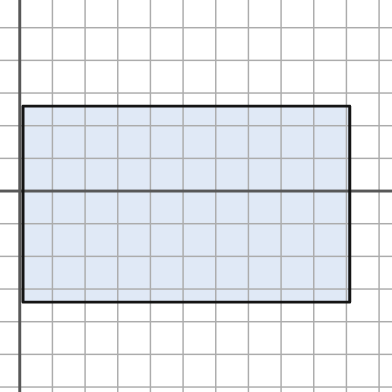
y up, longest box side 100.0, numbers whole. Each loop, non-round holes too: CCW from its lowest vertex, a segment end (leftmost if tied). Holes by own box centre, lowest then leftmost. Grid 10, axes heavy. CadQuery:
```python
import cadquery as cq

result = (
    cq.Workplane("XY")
    .moveTo(1.0, -34.0)
    .lineTo(101.0, -34.0)
    .lineTo(101.0, 26.0)
    .lineTo(1.0, 26.0)
    .close()
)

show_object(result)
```